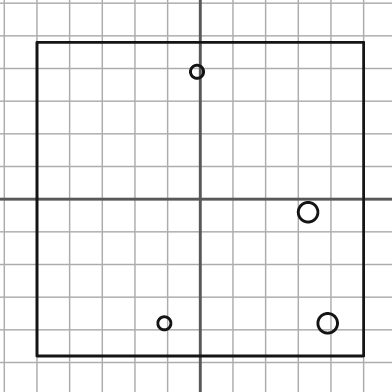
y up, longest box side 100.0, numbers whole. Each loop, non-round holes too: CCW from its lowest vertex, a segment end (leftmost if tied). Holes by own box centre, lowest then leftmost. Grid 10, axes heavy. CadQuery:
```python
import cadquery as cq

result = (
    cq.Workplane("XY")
    .moveTo(-50.0, -48.0)
    .lineTo(50.0, -48.0)
    .lineTo(50.0, 48.0)
    .lineTo(-50.0, 48.0)
    .close()
    .moveTo(-11.0, -38.0)
    .circle(2.0)
    .moveTo(39.0, -38.0)
    .circle(3.0)
    .moveTo(33.0, -4.0)
    .circle(3.0)
    .moveTo(-1.0, 39.0)
    .circle(2.0)
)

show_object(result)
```